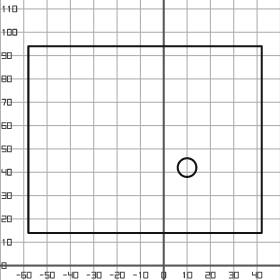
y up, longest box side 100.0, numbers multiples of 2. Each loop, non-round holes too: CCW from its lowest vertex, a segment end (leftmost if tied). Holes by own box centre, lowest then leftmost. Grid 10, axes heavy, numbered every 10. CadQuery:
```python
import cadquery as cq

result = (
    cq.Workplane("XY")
    .moveTo(-58.0, 14.0)
    .lineTo(42.0, 14.0)
    .lineTo(42.0, 94.0)
    .lineTo(-58.0, 94.0)
    .close()
    .moveTo(10.0, 42.0)
    .circle(4.0)
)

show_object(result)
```